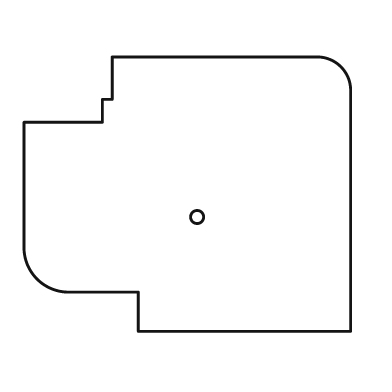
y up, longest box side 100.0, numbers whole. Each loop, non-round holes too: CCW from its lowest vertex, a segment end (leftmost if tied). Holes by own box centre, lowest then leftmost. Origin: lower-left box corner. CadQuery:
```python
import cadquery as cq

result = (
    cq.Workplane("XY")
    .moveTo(35.0, 0.0)
    .lineTo(100.0, 0.0)
    .lineTo(100.0, 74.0)
    .threePointArc((97.0, 81.0), (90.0, 84.0))
    .lineTo(27.0, 84.0)
    .lineTo(27.0, 71.0)
    .lineTo(24.0, 71.0)
    .lineTo(24.0, 64.0)
    .lineTo(0.0, 64.0)
    .lineTo(0.0, 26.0)
    .threePointArc((4.0, 16.0), (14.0, 12.0))
    .lineTo(35.0, 12.0)
    .close()
    .moveTo(53.0, 35.0)
    .circle(2.0)
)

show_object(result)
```